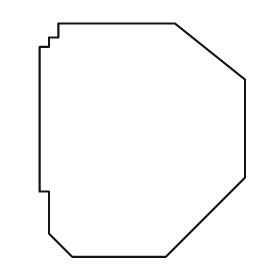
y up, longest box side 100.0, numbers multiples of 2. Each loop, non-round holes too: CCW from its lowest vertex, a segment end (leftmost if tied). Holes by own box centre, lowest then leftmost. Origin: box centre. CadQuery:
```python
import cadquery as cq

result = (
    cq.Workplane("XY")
    .moveTo(-30.0, -50.0)
    .lineTo(10.0, -50.0)
    .lineTo(44.0, -16.0)
    .lineTo(44.0, 26.0)
    .lineTo(14.0, 50.0)
    .lineTo(-36.0, 50.0)
    .lineTo(-36.0, 44.0)
    .lineTo(-40.0, 44.0)
    .lineTo(-40.0, 40.0)
    .lineTo(-44.0, 40.0)
    .lineTo(-44.0, -22.0)
    .lineTo(-40.0, -22.0)
    .lineTo(-40.0, -40.0)
    .close()
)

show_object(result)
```